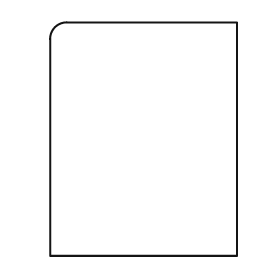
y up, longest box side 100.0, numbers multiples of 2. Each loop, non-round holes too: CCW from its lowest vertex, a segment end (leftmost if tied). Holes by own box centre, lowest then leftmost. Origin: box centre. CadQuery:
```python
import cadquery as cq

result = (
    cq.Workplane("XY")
    .moveTo(-40.0, -50.0)
    .lineTo(40.0, -50.0)
    .lineTo(40.0, 50.0)
    .lineTo(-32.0, 50.0)
    .threePointArc((-38.0, 48.0), (-40.0, 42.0))
    .close()
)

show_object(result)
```